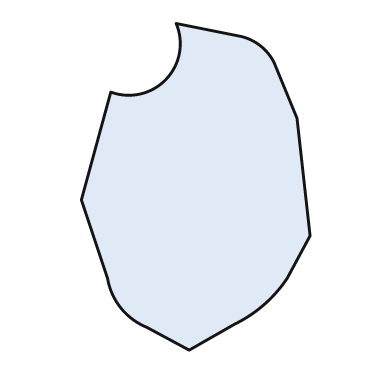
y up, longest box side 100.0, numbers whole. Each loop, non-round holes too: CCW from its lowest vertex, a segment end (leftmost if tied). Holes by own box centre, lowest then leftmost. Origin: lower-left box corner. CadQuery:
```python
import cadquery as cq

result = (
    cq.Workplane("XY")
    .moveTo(33.0, 0.0)
    .lineTo(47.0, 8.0)
    .threePointArc((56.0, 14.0), (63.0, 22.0))
    .lineTo(70.0, 35.0)
    .lineTo(66.0, 71.0)
    .lineTo(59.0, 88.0)
    .threePointArc((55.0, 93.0), (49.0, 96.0))
    .lineTo(29.0, 100.0)
    .threePointArc((26.0, 83.0), (9.0, 79.0))
    .lineTo(0.0, 46.0)
    .lineTo(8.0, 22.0)
    .threePointArc((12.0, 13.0), (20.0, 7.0))
    .close()
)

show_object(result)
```